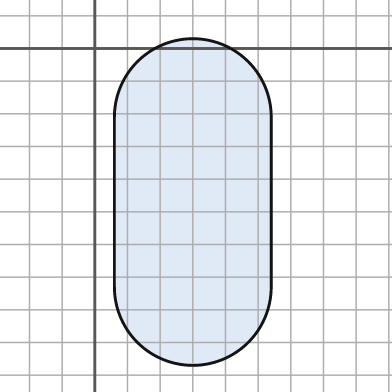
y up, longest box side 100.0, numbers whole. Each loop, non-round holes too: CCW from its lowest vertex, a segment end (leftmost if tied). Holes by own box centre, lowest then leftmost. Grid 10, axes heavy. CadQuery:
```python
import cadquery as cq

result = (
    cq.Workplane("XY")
    .moveTo(6.0, -73.0)
    .threePointArc((30.0, -97.0), (54.0, -73.0))
    .lineTo(54.0, -21.0)
    .threePointArc((30.0, 3.0), (6.0, -21.0))
    .close()
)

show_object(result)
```